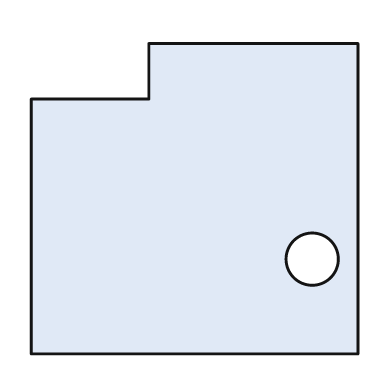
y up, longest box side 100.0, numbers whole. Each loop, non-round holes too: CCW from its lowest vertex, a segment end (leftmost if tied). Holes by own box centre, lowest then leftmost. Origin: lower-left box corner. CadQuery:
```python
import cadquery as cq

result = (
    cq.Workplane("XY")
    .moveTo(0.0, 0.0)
    .lineTo(100.0, 0.0)
    .lineTo(100.0, 95.0)
    .lineTo(36.0, 95.0)
    .lineTo(36.0, 78.0)
    .lineTo(0.0, 78.0)
    .close()
    .moveTo(86.0, 29.0)
    .circle(8.0)
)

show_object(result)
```